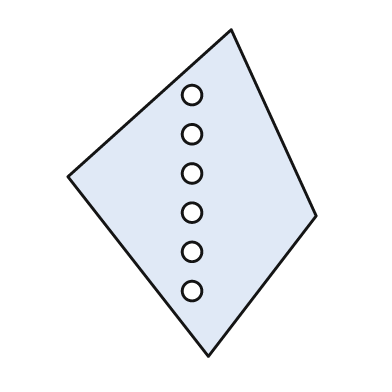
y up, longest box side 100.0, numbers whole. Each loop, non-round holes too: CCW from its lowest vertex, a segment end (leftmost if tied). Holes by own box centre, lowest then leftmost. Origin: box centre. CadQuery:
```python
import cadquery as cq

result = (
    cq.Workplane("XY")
    .moveTo(5.0, -50.0)
    .lineTo(38.0, -7.0)
    .lineTo(12.0, 50.0)
    .lineTo(-38.0, 5.0)
    .close()
    .moveTo(0.0, -30.0)
    .circle(3.0)
    .moveTo(0.0, -18.0)
    .circle(3.0)
    .moveTo(0.0, -6.0)
    .circle(3.0)
    .moveTo(0.0, 6.0)
    .circle(3.0)
    .moveTo(0.0, 18.0)
    .circle(3.0)
    .moveTo(0.0, 30.0)
    .circle(3.0)
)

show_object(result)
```